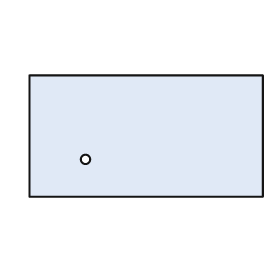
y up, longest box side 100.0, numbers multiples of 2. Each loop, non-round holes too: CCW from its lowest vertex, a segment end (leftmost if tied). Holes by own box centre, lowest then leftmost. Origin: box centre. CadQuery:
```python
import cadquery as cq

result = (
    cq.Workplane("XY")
    .moveTo(-50.0, -26.0)
    .lineTo(50.0, -26.0)
    .lineTo(50.0, 26.0)
    .lineTo(-50.0, 26.0)
    .close()
    .moveTo(-26.0, -10.0)
    .circle(2.0)
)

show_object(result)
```